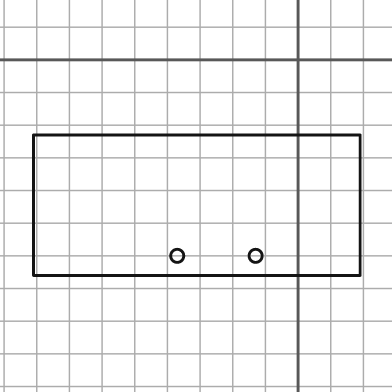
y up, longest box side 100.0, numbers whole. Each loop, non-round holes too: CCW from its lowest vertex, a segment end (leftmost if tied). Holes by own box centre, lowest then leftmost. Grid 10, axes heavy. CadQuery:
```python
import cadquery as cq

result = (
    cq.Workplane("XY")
    .moveTo(-81.0, -66.0)
    .lineTo(19.0, -66.0)
    .lineTo(19.0, -23.0)
    .lineTo(-81.0, -23.0)
    .close()
    .moveTo(-37.0, -60.0)
    .circle(2.0)
    .moveTo(-13.0, -60.0)
    .circle(2.0)
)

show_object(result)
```